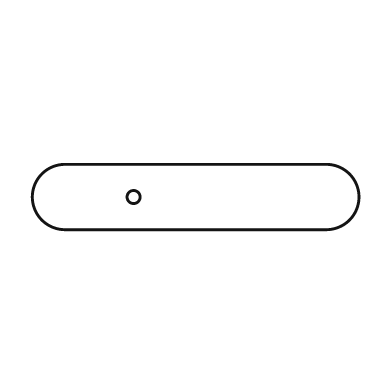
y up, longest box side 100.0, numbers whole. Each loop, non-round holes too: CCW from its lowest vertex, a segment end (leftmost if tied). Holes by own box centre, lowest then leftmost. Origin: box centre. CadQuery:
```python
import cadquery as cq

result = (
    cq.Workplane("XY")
    .moveTo(-40.0, -10.0)
    .lineTo(40.0, -10.0)
    .threePointArc((50.0, 0.0), (40.0, 10.0))
    .lineTo(-40.0, 10.0)
    .threePointArc((-50.0, 0.0), (-40.0, -10.0))
    .close()
    .moveTo(-19.0, 0.0)
    .circle(2.0)
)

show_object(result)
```